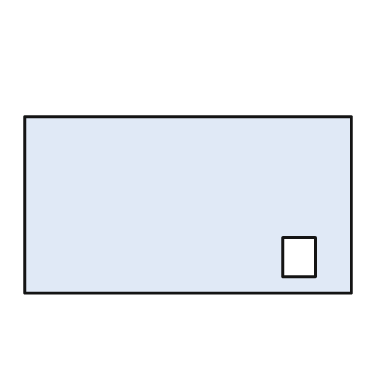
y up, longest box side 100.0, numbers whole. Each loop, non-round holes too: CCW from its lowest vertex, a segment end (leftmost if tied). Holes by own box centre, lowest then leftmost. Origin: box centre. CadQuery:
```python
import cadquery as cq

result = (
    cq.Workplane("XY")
    .moveTo(-50.0, -27.0)
    .lineTo(50.0, -27.0)
    .lineTo(50.0, 27.0)
    .lineTo(-50.0, 27.0)
    .close()
    .moveTo(29.0, -22.0)
    .lineTo(39.0, -22.0)
    .lineTo(39.0, -10.0)
    .lineTo(29.0, -10.0)
    .close()
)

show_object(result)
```